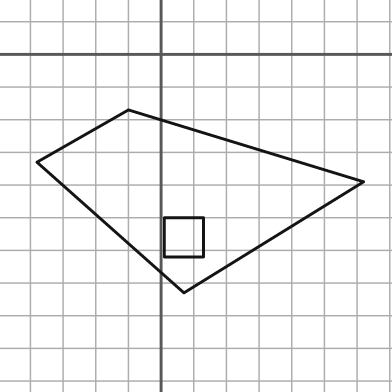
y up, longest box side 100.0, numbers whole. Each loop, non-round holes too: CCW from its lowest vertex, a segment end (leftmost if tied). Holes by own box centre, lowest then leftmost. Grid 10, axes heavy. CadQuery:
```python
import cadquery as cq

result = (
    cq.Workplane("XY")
    .moveTo(7.0, -73.0)
    .lineTo(62.0, -39.0)
    .lineTo(-10.0, -17.0)
    .lineTo(-38.0, -33.0)
    .close()
    .moveTo(1.0, -62.0)
    .lineTo(13.0, -62.0)
    .lineTo(13.0, -50.0)
    .lineTo(1.0, -50.0)
    .close()
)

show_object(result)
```